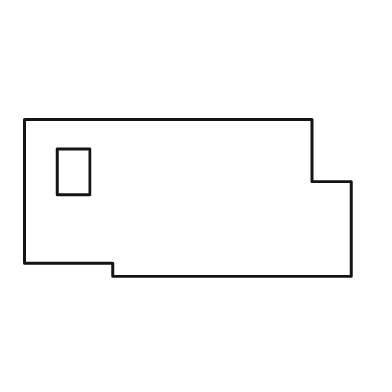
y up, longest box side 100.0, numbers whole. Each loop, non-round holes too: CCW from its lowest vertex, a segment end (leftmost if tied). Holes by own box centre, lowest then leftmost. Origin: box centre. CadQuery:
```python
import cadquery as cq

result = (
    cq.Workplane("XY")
    .moveTo(-23.0, -24.0)
    .lineTo(50.0, -24.0)
    .lineTo(50.0, 5.0)
    .lineTo(38.0, 5.0)
    .lineTo(38.0, 24.0)
    .lineTo(-50.0, 24.0)
    .lineTo(-50.0, -20.0)
    .lineTo(-23.0, -20.0)
    .close()
    .moveTo(-40.0, 1.0)
    .lineTo(-30.0, 1.0)
    .lineTo(-30.0, 15.0)
    .lineTo(-40.0, 15.0)
    .close()
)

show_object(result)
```